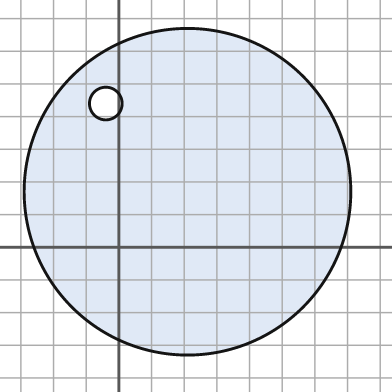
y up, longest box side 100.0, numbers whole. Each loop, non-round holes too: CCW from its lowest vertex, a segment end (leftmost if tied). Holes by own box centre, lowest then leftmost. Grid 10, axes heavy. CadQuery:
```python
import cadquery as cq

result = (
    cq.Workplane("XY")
    .moveTo(21.0, 17.0)
    .circle(50.0)
    .moveTo(-4.0, 44.0)
    .circle(5.0)
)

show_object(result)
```